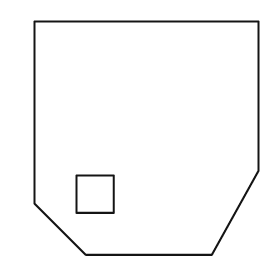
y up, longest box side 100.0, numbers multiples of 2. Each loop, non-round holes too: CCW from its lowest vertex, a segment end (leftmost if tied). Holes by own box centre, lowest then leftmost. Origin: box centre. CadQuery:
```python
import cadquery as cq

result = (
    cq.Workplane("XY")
    .moveTo(-26.0, -50.0)
    .lineTo(28.0, -50.0)
    .lineTo(48.0, -14.0)
    .lineTo(48.0, 50.0)
    .lineTo(-48.0, 50.0)
    .lineTo(-48.0, -28.0)
    .close()
    .moveTo(-30.0, -32.0)
    .lineTo(-14.0, -32.0)
    .lineTo(-14.0, -16.0)
    .lineTo(-30.0, -16.0)
    .close()
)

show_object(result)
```